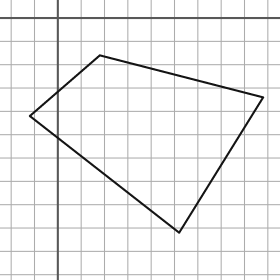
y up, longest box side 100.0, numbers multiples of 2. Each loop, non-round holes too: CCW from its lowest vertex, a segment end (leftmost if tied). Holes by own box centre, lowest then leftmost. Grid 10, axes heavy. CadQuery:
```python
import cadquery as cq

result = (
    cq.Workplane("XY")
    .moveTo(52.0, -92.0)
    .lineTo(88.0, -34.0)
    .lineTo(18.0, -16.0)
    .lineTo(-12.0, -42.0)
    .close()
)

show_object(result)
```